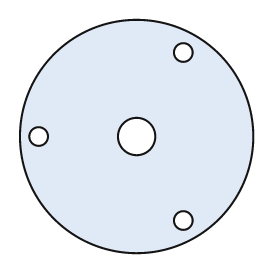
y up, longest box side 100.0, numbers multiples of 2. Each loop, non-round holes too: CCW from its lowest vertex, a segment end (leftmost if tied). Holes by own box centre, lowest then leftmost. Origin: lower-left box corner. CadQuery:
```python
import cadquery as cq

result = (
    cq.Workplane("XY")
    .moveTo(50.0, 50.0)
    .circle(50.0)
    .moveTo(70.0, 14.0)
    .circle(4.0)
    .moveTo(8.0, 50.0)
    .circle(4.0)
    .moveTo(50.0, 50.0)
    .circle(8.0)
    .moveTo(70.0, 86.0)
    .circle(4.0)
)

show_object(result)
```